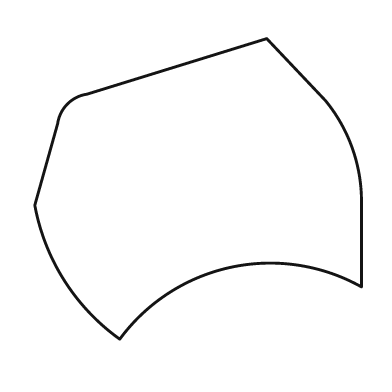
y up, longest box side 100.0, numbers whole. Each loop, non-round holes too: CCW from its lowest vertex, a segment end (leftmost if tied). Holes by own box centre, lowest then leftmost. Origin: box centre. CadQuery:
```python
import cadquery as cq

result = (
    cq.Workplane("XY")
    .moveTo(-24.0, -46.0)
    .threePointArc((10.0, -24.0), (50.0, -30.0))
    .lineTo(50.0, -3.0)
    .threePointArc((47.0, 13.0), (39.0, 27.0))
    .lineTo(21.0, 46.0)
    .lineTo(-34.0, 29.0)
    .threePointArc((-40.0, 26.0), (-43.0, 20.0))
    .lineTo(-50.0, -5.0)
    .threePointArc((-41.0, -28.0), (-24.0, -46.0))
    .close()
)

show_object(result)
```